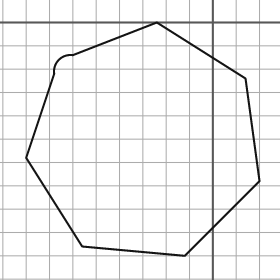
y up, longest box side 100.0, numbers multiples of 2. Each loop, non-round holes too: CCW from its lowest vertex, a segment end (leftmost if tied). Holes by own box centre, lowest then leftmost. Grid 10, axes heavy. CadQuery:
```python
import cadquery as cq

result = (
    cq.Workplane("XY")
    .moveTo(-12.0, -100.0)
    .lineTo(20.0, -68.0)
    .lineTo(14.0, -24.0)
    .lineTo(-24.0, 0.0)
    .lineTo(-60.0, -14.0)
    .threePointArc((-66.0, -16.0), (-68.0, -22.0))
    .lineTo(-80.0, -58.0)
    .lineTo(-56.0, -96.0)
    .close()
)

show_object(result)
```